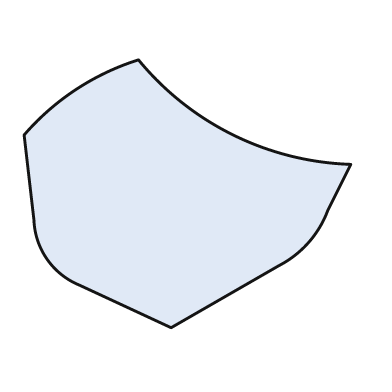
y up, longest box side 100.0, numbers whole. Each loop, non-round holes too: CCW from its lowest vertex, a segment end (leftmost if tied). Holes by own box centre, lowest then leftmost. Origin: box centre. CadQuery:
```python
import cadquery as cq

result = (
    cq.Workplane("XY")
    .moveTo(-5.0, -41.0)
    .lineTo(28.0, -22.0)
    .threePointArc((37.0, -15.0), (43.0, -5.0))
    .lineTo(50.0, 9.0)
    .threePointArc((14.0, 18.0), (-15.0, 41.0))
    .threePointArc((-34.0, 32.0), (-50.0, 18.0))
    .lineTo(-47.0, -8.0)
    .threePointArc((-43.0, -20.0), (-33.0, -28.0))
    .close()
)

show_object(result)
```